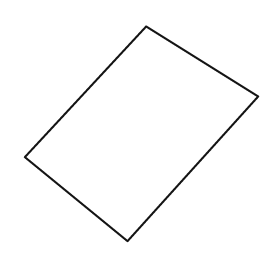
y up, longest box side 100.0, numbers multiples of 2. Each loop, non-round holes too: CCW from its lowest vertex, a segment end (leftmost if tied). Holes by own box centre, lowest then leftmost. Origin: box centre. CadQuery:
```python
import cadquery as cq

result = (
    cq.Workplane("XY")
    .moveTo(-6.0, -46.0)
    .lineTo(50.0, 16.0)
    .lineTo(2.0, 46.0)
    .lineTo(-50.0, -10.0)
    .close()
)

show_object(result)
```